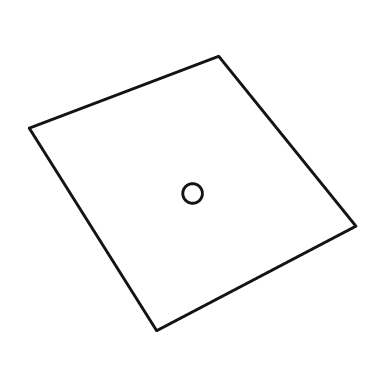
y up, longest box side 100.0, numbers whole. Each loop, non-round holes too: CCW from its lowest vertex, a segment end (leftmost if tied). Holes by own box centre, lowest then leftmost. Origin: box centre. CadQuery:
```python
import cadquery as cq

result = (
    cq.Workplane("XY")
    .moveTo(-11.0, -42.0)
    .lineTo(50.0, -10.0)
    .lineTo(8.0, 42.0)
    .lineTo(-50.0, 20.0)
    .close()
    .moveTo(0.0, 0.0)
    .circle(3.0)
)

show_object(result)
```